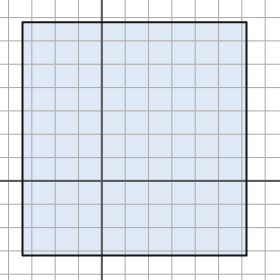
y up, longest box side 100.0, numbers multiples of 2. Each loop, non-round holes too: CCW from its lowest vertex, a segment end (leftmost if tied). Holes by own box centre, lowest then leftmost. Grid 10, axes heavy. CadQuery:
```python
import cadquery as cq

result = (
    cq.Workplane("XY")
    .moveTo(-34.0, -32.0)
    .lineTo(62.0, -32.0)
    .lineTo(62.0, 68.0)
    .lineTo(-34.0, 68.0)
    .close()
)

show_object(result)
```